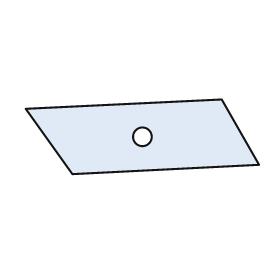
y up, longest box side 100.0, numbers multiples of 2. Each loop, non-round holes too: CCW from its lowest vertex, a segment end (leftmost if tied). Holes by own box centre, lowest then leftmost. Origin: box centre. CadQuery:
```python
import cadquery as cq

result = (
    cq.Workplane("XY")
    .moveTo(-30.0, -16.0)
    .lineTo(50.0, -12.0)
    .lineTo(34.0, 16.0)
    .lineTo(-50.0, 12.0)
    .close()
    .moveTo(0.0, 0.0)
    .circle(4.0)
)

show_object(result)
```